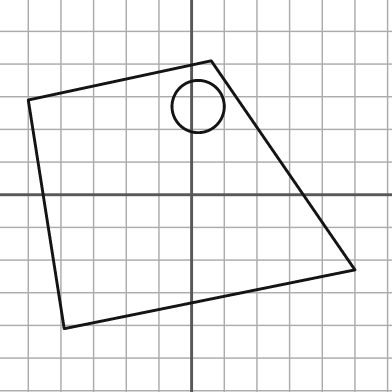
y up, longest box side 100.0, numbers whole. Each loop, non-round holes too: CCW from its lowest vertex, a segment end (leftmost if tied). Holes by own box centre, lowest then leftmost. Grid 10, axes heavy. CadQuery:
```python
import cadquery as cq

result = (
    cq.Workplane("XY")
    .moveTo(-39.0, -41.0)
    .lineTo(50.0, -23.0)
    .lineTo(6.0, 41.0)
    .lineTo(-50.0, 29.0)
    .close()
    .moveTo(2.0, 27.0)
    .circle(8.0)
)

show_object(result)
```